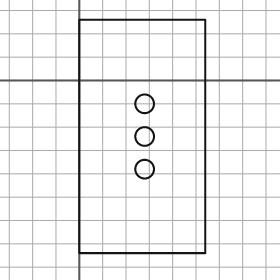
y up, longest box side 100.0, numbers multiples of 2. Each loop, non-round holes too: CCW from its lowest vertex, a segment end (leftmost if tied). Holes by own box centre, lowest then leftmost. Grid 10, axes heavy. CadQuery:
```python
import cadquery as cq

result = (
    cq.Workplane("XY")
    .moveTo(0.0, -74.0)
    .lineTo(54.0, -74.0)
    .lineTo(54.0, 26.0)
    .lineTo(0.0, 26.0)
    .close()
    .moveTo(28.0, -38.0)
    .circle(4.0)
    .moveTo(28.0, -24.0)
    .circle(4.0)
    .moveTo(28.0, -10.0)
    .circle(4.0)
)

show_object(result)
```